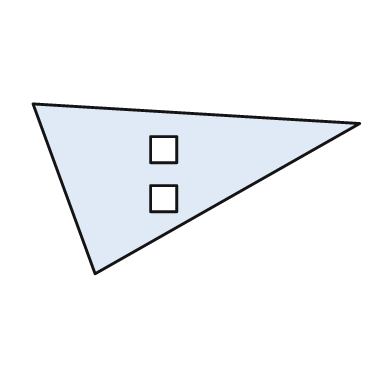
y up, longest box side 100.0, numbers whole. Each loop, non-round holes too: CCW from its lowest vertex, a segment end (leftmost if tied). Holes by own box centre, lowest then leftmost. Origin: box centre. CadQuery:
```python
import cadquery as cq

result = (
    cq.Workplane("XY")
    .moveTo(-31.0, -26.0)
    .lineTo(50.0, 20.0)
    .lineTo(-50.0, 26.0)
    .close()
    .moveTo(-14.0, -7.0)
    .lineTo(-6.0, -7.0)
    .lineTo(-6.0, 1.0)
    .lineTo(-14.0, 1.0)
    .close()
    .moveTo(-14.0, 8.0)
    .lineTo(-6.0, 8.0)
    .lineTo(-6.0, 16.0)
    .lineTo(-14.0, 16.0)
    .close()
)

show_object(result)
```